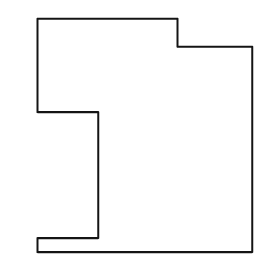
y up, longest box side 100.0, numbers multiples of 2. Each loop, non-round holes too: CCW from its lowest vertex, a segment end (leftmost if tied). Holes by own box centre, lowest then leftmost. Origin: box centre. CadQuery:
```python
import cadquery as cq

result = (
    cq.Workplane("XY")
    .moveTo(-46.0, -50.0)
    .lineTo(46.0, -50.0)
    .lineTo(46.0, 38.0)
    .lineTo(14.0, 38.0)
    .lineTo(14.0, 50.0)
    .lineTo(-46.0, 50.0)
    .lineTo(-46.0, 10.0)
    .lineTo(-20.0, 10.0)
    .lineTo(-20.0, -44.0)
    .lineTo(-46.0, -44.0)
    .close()
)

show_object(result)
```